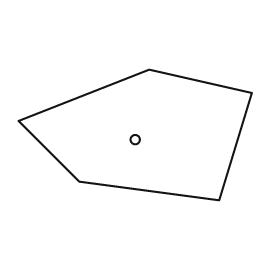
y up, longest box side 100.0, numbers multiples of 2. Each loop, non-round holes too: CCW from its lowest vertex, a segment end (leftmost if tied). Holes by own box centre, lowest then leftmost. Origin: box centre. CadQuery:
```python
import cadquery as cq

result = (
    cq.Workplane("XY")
    .moveTo(36.0, -28.0)
    .lineTo(50.0, 18.0)
    .lineTo(6.0, 28.0)
    .lineTo(-50.0, 6.0)
    .lineTo(-24.0, -20.0)
    .close()
    .moveTo(0.0, -2.0)
    .circle(2.0)
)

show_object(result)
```